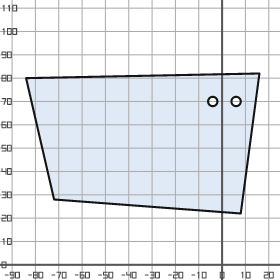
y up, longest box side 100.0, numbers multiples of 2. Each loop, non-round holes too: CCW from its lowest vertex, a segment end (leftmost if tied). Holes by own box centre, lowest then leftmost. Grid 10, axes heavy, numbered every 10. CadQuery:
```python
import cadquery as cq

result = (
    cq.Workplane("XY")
    .moveTo(8.0, 22.0)
    .lineTo(16.0, 82.0)
    .lineTo(-84.0, 80.0)
    .lineTo(-72.0, 28.0)
    .close()
    .moveTo(-4.0, 70.0)
    .circle(2.0)
    .moveTo(6.0, 70.0)
    .circle(2.0)
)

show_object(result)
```